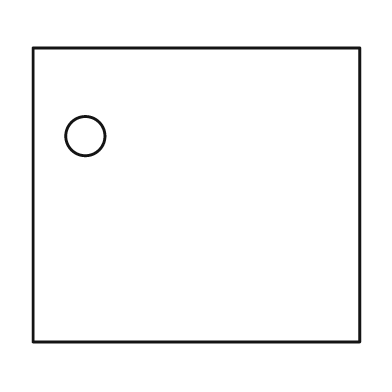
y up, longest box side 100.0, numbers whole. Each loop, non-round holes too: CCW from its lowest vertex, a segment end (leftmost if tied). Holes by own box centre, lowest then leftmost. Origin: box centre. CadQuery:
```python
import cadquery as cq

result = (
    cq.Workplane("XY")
    .moveTo(-50.0, -45.0)
    .lineTo(50.0, -45.0)
    .lineTo(50.0, 45.0)
    .lineTo(-50.0, 45.0)
    .close()
    .moveTo(-34.0, 18.0)
    .circle(6.0)
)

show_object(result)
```